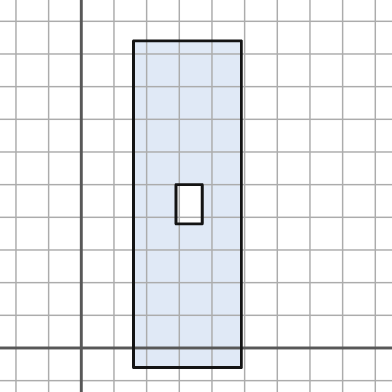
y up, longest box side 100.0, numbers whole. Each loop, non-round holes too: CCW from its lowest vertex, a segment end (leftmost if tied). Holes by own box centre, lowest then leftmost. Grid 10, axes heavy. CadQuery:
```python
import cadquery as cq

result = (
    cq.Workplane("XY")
    .moveTo(16.0, -6.0)
    .lineTo(49.0, -6.0)
    .lineTo(49.0, 94.0)
    .lineTo(16.0, 94.0)
    .close()
    .moveTo(29.0, 38.0)
    .lineTo(37.0, 38.0)
    .lineTo(37.0, 50.0)
    .lineTo(29.0, 50.0)
    .close()
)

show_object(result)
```